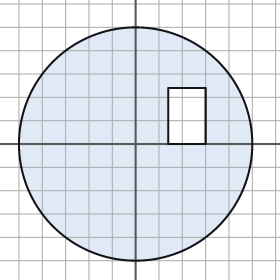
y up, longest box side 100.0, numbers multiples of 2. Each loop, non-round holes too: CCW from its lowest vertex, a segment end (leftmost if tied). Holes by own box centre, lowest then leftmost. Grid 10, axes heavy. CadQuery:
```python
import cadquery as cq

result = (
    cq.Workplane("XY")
    .moveTo(0.0, 0.0)
    .circle(50.0)
    .moveTo(14.0, 0.0)
    .lineTo(30.0, 0.0)
    .lineTo(30.0, 24.0)
    .lineTo(14.0, 24.0)
    .close()
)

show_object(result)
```